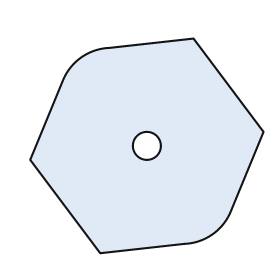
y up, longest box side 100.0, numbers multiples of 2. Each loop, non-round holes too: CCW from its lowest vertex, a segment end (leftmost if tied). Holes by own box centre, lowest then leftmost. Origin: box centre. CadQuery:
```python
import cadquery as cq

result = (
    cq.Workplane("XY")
    .moveTo(-20.0, -46.0)
    .lineTo(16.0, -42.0)
    .threePointArc((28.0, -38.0), (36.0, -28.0))
    .lineTo(50.0, 6.0)
    .lineTo(20.0, 46.0)
    .lineTo(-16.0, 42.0)
    .threePointArc((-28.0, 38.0), (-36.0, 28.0))
    .lineTo(-50.0, -6.0)
    .close()
    .moveTo(0.0, 0.0)
    .circle(6.0)
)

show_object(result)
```